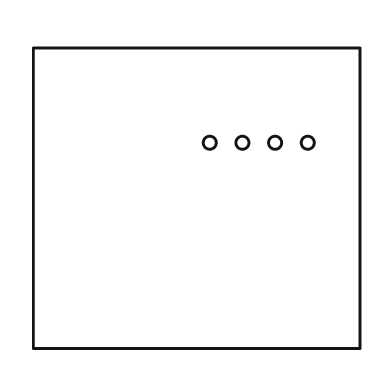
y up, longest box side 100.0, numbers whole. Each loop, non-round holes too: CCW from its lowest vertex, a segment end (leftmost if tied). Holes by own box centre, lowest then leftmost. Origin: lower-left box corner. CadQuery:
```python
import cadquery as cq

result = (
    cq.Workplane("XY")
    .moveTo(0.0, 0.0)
    .lineTo(100.0, 0.0)
    .lineTo(100.0, 92.0)
    .lineTo(0.0, 92.0)
    .close()
    .moveTo(54.0, 63.0)
    .circle(2.0)
    .moveTo(64.0, 63.0)
    .circle(2.0)
    .moveTo(74.0, 63.0)
    .circle(2.0)
    .moveTo(84.0, 63.0)
    .circle(2.0)
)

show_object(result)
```